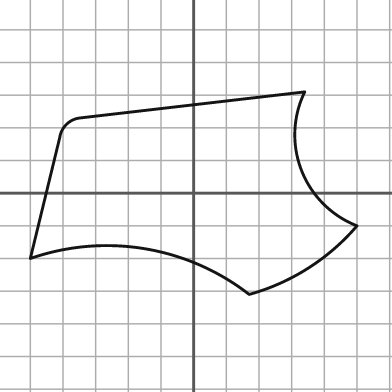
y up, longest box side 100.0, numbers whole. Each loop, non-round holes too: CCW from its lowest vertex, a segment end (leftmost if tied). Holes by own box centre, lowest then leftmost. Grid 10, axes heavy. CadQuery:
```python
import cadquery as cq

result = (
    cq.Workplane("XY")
    .moveTo(17.0, -31.0)
    .threePointArc((35.0, -23.0), (50.0, -10.0))
    .threePointArc((33.0, 7.0), (34.0, 31.0))
    .lineTo(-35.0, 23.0)
    .threePointArc((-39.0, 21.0), (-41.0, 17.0))
    .lineTo(-50.0, -20.0)
    .threePointArc((-15.0, -17.0), (17.0, -31.0))
    .close()
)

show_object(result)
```